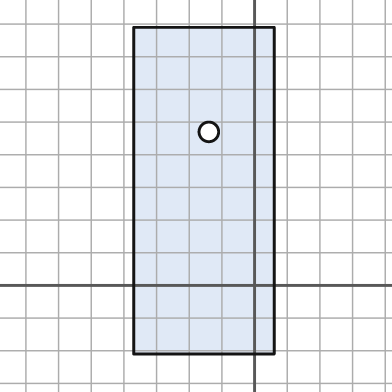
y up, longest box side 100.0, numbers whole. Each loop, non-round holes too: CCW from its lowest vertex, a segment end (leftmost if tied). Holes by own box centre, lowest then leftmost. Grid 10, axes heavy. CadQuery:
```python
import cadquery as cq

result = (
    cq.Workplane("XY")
    .moveTo(-37.0, -21.0)
    .lineTo(6.0, -21.0)
    .lineTo(6.0, 79.0)
    .lineTo(-37.0, 79.0)
    .close()
    .moveTo(-14.0, 47.0)
    .circle(3.0)
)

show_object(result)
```